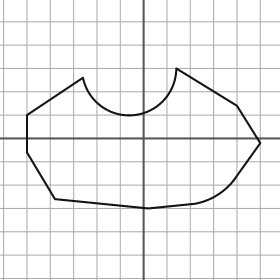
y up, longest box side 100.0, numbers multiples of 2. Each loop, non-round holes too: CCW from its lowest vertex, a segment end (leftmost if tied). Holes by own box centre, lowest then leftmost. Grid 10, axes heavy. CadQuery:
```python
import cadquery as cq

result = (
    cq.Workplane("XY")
    .moveTo(2.0, -30.0)
    .lineTo(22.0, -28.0)
    .threePointArc((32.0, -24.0), (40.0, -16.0))
    .lineTo(50.0, -2.0)
    .lineTo(40.0, 14.0)
    .lineTo(14.0, 30.0)
    .threePointArc((-4.0, 10.0), (-26.0, 26.0))
    .lineTo(-50.0, 10.0)
    .lineTo(-50.0, -6.0)
    .lineTo(-38.0, -26.0)
    .close()
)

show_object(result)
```